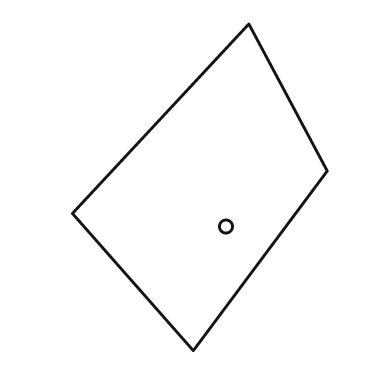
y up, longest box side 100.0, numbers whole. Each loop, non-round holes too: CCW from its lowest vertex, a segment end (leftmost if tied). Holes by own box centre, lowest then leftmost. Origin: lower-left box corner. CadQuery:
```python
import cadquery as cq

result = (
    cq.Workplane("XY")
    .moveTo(37.0, 0.0)
    .lineTo(78.0, 55.0)
    .lineTo(54.0, 100.0)
    .lineTo(0.0, 42.0)
    .close()
    .moveTo(47.0, 38.0)
    .circle(2.0)
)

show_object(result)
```